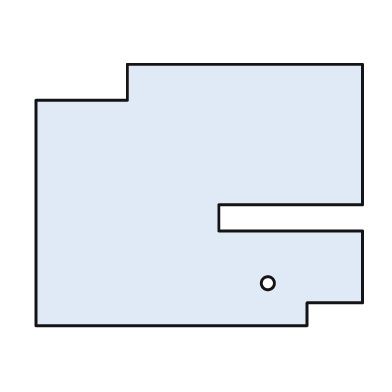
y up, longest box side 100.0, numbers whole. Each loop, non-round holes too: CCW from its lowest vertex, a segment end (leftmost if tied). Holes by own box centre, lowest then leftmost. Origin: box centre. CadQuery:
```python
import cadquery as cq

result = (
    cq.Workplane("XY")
    .moveTo(-50.0, -40.0)
    .lineTo(33.0, -40.0)
    .lineTo(33.0, -33.0)
    .lineTo(50.0, -33.0)
    .lineTo(50.0, -11.0)
    .lineTo(6.0, -11.0)
    .lineTo(6.0, -3.0)
    .lineTo(50.0, -3.0)
    .lineTo(50.0, 40.0)
    .lineTo(-22.0, 40.0)
    .lineTo(-22.0, 29.0)
    .lineTo(-50.0, 29.0)
    .close()
    .moveTo(21.0, -27.0)
    .circle(2.0)
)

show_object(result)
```